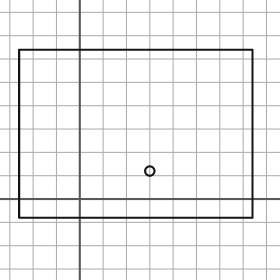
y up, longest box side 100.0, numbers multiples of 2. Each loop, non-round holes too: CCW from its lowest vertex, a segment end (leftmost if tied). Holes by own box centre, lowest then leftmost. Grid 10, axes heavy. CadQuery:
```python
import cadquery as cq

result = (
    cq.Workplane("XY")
    .moveTo(-26.0, -8.0)
    .lineTo(74.0, -8.0)
    .lineTo(74.0, 64.0)
    .lineTo(-26.0, 64.0)
    .close()
    .moveTo(30.0, 12.0)
    .circle(2.0)
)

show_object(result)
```